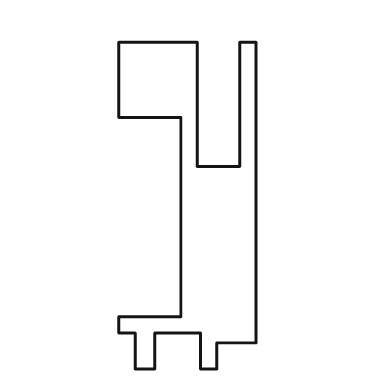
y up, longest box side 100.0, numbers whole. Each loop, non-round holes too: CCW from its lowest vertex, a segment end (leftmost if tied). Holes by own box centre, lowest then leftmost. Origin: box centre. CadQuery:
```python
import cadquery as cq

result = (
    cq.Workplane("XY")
    .moveTo(-16.0, -50.0)
    .lineTo(-10.0, -50.0)
    .lineTo(-10.0, -39.0)
    .lineTo(4.0, -39.0)
    .lineTo(4.0, -50.0)
    .lineTo(9.0, -50.0)
    .lineTo(9.0, -42.0)
    .lineTo(21.0, -42.0)
    .lineTo(21.0, 50.0)
    .lineTo(16.0, 50.0)
    .lineTo(16.0, 12.0)
    .lineTo(3.0, 12.0)
    .lineTo(3.0, 50.0)
    .lineTo(-21.0, 50.0)
    .lineTo(-21.0, 27.0)
    .lineTo(-2.0, 27.0)
    .lineTo(-2.0, -34.0)
    .lineTo(-21.0, -34.0)
    .lineTo(-21.0, -39.0)
    .lineTo(-16.0, -39.0)
    .close()
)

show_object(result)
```